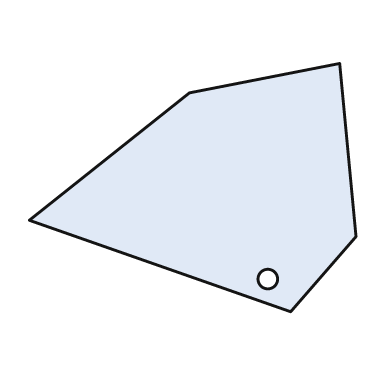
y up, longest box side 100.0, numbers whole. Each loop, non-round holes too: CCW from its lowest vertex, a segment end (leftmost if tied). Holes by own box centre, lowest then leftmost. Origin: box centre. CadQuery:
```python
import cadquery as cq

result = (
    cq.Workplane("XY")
    .moveTo(30.0, -38.0)
    .lineTo(50.0, -15.0)
    .lineTo(45.0, 38.0)
    .lineTo(-1.0, 29.0)
    .lineTo(-50.0, -10.0)
    .close()
    .moveTo(23.0, -28.0)
    .circle(3.0)
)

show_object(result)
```